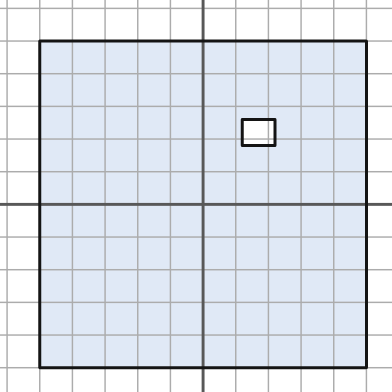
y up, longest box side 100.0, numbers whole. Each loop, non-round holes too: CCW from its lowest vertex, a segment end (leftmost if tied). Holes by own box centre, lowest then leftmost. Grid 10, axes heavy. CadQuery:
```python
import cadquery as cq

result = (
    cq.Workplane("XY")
    .moveTo(-50.0, -50.0)
    .lineTo(50.0, -50.0)
    .lineTo(50.0, 50.0)
    .lineTo(-50.0, 50.0)
    .close()
    .moveTo(12.0, 18.0)
    .lineTo(22.0, 18.0)
    .lineTo(22.0, 26.0)
    .lineTo(12.0, 26.0)
    .close()
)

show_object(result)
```